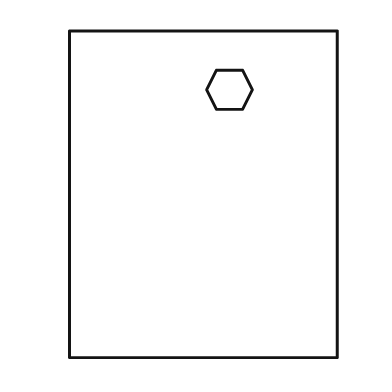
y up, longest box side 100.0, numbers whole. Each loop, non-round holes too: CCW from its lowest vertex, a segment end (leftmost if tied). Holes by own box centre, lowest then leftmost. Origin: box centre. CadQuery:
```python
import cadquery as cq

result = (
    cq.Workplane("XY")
    .moveTo(-41.0, -50.0)
    .lineTo(41.0, -50.0)
    .lineTo(41.0, 50.0)
    .lineTo(-41.0, 50.0)
    .close()
    .moveTo(4.0, 26.0)
    .lineTo(12.0, 26.0)
    .lineTo(15.0, 32.0)
    .lineTo(12.0, 38.0)
    .lineTo(4.0, 38.0)
    .lineTo(1.0, 32.0)
    .close()
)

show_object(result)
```